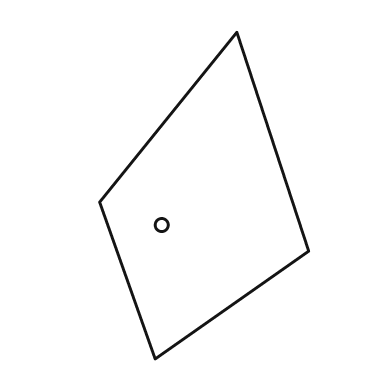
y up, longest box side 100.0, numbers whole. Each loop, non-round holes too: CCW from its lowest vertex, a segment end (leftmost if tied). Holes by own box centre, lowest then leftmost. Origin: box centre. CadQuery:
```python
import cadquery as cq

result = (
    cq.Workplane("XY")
    .moveTo(-15.0, -50.0)
    .lineTo(32.0, -17.0)
    .lineTo(10.0, 50.0)
    .lineTo(-32.0, -2.0)
    .close()
    .moveTo(-13.0, -9.0)
    .circle(2.0)
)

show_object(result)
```